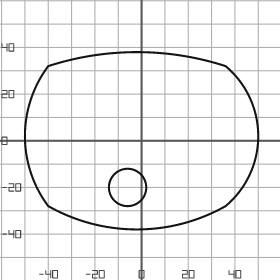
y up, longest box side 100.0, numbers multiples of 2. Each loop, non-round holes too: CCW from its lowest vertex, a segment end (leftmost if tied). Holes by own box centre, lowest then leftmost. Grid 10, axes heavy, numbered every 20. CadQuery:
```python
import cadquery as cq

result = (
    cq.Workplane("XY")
    .moveTo(-40.0, -28.0)
    .threePointArc((-2.0, -38.0), (36.0, -28.0))
    .threePointArc((50.0, 2.0), (36.0, 32.0))
    .threePointArc((-2.0, 38.0), (-40.0, 32.0))
    .threePointArc((-50.0, 2.0), (-40.0, -28.0))
    .close()
    .moveTo(-6.0, -20.0)
    .circle(8.0)
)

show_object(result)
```